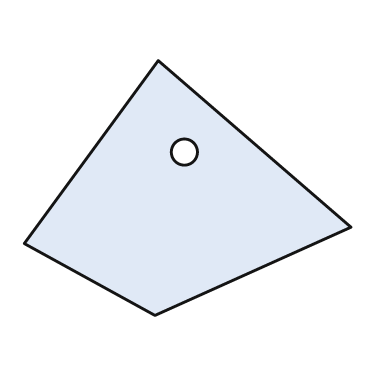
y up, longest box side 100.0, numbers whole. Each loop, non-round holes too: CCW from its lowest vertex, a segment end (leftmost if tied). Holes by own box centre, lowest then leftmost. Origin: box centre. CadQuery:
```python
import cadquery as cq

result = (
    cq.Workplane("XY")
    .moveTo(-10.0, -39.0)
    .lineTo(50.0, -12.0)
    .lineTo(-9.0, 39.0)
    .lineTo(-50.0, -17.0)
    .close()
    .moveTo(-1.0, 11.0)
    .circle(4.0)
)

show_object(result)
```